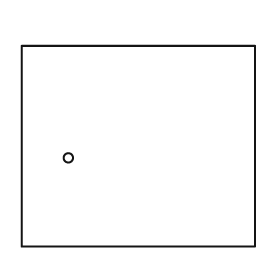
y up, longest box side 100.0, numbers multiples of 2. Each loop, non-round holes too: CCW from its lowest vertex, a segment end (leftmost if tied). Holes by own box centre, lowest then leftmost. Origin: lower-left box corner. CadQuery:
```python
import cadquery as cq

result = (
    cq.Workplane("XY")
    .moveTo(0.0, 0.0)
    .lineTo(100.0, 0.0)
    .lineTo(100.0, 86.0)
    .lineTo(0.0, 86.0)
    .close()
    .moveTo(20.0, 38.0)
    .circle(2.0)
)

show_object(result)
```